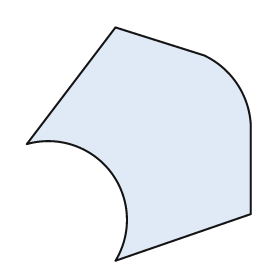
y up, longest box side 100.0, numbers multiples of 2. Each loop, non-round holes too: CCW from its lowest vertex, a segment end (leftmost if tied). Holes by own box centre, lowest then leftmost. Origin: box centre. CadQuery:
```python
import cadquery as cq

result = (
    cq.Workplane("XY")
    .moveTo(-10.0, -50.0)
    .lineTo(48.0, -30.0)
    .lineTo(48.0, 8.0)
    .threePointArc((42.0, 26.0), (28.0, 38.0))
    .lineTo(-10.0, 50.0)
    .lineTo(-48.0, 0.0)
    .threePointArc((-12.0, -12.0), (-10.0, -50.0))
    .close()
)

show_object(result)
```